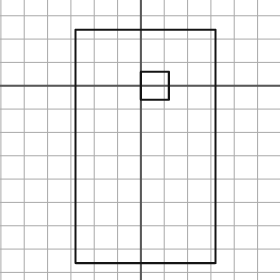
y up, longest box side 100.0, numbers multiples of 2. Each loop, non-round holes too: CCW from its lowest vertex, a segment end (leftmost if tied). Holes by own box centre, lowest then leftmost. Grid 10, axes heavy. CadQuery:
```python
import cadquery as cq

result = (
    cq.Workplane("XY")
    .moveTo(-28.0, -76.0)
    .lineTo(32.0, -76.0)
    .lineTo(32.0, 24.0)
    .lineTo(-28.0, 24.0)
    .close()
    .moveTo(0.0, -6.0)
    .lineTo(12.0, -6.0)
    .lineTo(12.0, 6.0)
    .lineTo(0.0, 6.0)
    .close()
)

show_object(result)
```